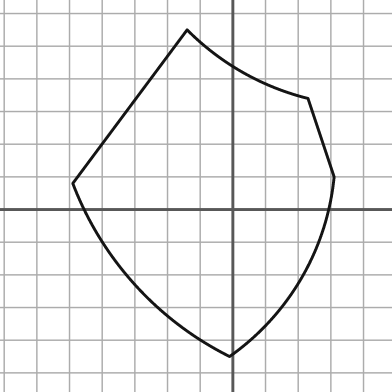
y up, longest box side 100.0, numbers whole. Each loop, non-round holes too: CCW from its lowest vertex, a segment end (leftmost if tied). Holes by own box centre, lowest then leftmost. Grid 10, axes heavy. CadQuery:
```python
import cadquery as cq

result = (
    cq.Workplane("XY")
    .moveTo(-1.0, -45.0)
    .threePointArc((21.0, -21.0), (31.0, 10.0))
    .lineTo(23.0, 34.0)
    .threePointArc((3.0, 42.0), (-14.0, 55.0))
    .lineTo(-49.0, 8.0)
    .threePointArc((-30.0, -23.0), (-1.0, -45.0))
    .close()
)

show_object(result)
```